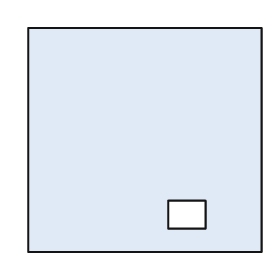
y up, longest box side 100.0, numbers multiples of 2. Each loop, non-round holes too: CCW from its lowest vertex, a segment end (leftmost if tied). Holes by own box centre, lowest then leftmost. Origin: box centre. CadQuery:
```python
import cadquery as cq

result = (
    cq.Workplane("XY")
    .moveTo(-50.0, -48.0)
    .lineTo(50.0, -48.0)
    .lineTo(50.0, 48.0)
    .lineTo(-50.0, 48.0)
    .close()
    .moveTo(10.0, -38.0)
    .lineTo(26.0, -38.0)
    .lineTo(26.0, -26.0)
    .lineTo(10.0, -26.0)
    .close()
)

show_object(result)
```